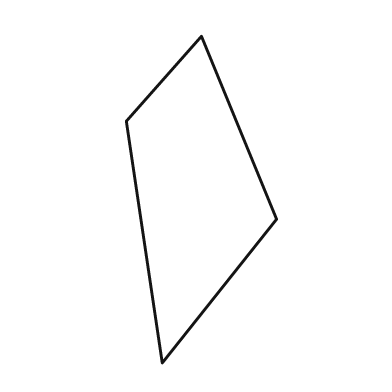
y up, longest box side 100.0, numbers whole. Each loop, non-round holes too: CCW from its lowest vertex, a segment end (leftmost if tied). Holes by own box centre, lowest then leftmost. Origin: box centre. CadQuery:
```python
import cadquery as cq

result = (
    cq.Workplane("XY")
    .moveTo(-12.0, -50.0)
    .lineTo(23.0, -6.0)
    .lineTo(0.0, 50.0)
    .lineTo(-23.0, 24.0)
    .close()
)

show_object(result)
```